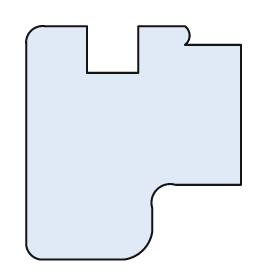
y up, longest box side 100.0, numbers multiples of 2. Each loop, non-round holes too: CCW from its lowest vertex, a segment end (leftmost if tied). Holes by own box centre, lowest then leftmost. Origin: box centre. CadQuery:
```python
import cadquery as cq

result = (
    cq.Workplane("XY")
    .moveTo(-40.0, -50.0)
    .lineTo(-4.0, -50.0)
    .threePointArc((4.0, -46.0), (8.0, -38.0))
    .lineTo(8.0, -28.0)
    .threePointArc((10.0, -20.0), (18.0, -18.0))
    .lineTo(46.0, -18.0)
    .lineTo(46.0, 42.0)
    .lineTo(22.0, 42.0)
    .threePointArc((24.0, 46.0), (22.0, 50.0))
    .lineTo(2.0, 50.0)
    .lineTo(2.0, 30.0)
    .lineTo(-20.0, 30.0)
    .lineTo(-20.0, 50.0)
    .lineTo(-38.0, 50.0)
    .threePointArc((-44.0, 48.0), (-46.0, 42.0))
    .lineTo(-46.0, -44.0)
    .threePointArc((-44.0, -48.0), (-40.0, -50.0))
    .close()
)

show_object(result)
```